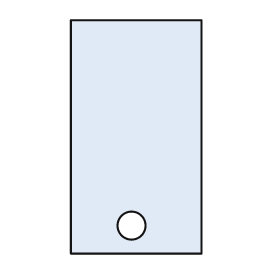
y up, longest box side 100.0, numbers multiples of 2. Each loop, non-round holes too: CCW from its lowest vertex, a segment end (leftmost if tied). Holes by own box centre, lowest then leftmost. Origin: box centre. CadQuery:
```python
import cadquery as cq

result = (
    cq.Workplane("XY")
    .moveTo(-28.0, -50.0)
    .lineTo(28.0, -50.0)
    .lineTo(28.0, 50.0)
    .lineTo(-28.0, 50.0)
    .close()
    .moveTo(-2.0, -38.0)
    .circle(6.0)
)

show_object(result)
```